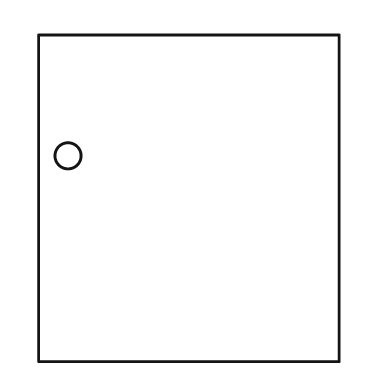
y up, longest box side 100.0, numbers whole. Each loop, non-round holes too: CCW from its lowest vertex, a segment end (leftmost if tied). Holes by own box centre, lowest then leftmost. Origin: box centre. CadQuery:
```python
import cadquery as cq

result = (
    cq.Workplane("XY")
    .moveTo(-46.0, -50.0)
    .lineTo(46.0, -50.0)
    .lineTo(46.0, 50.0)
    .lineTo(-46.0, 50.0)
    .close()
    .moveTo(-37.0, 13.0)
    .circle(4.0)
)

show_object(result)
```